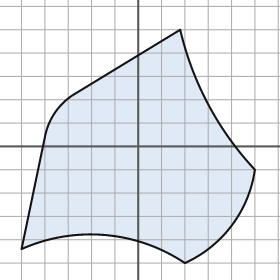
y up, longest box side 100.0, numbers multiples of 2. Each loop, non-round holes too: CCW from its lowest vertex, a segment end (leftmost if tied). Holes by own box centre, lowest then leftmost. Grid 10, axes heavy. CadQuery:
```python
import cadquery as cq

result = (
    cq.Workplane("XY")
    .moveTo(20.0, -50.0)
    .threePointArc((40.0, -34.0), (50.0, -10.0))
    .threePointArc((30.0, 18.0), (18.0, 50.0))
    .lineTo(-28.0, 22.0)
    .threePointArc((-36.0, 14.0), (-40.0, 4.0))
    .lineTo(-50.0, -44.0)
    .threePointArc((-14.0, -38.0), (20.0, -50.0))
    .close()
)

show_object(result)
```